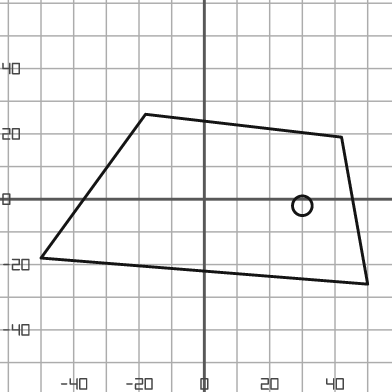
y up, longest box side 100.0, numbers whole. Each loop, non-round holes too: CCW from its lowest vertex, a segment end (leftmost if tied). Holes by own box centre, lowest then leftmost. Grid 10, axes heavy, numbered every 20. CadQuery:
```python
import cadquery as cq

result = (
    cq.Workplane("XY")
    .moveTo(50.0, -26.0)
    .lineTo(42.0, 19.0)
    .lineTo(-18.0, 26.0)
    .lineTo(-50.0, -18.0)
    .close()
    .moveTo(30.0, -2.0)
    .circle(3.0)
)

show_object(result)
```